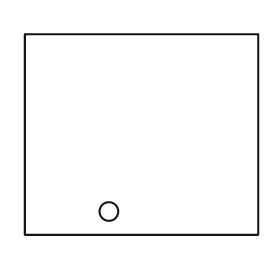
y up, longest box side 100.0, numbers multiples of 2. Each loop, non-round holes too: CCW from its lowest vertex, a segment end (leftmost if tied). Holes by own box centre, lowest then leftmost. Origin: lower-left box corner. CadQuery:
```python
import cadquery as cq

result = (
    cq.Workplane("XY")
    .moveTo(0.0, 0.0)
    .lineTo(100.0, 0.0)
    .lineTo(100.0, 86.0)
    .lineTo(0.0, 86.0)
    .close()
    .moveTo(36.0, 10.0)
    .circle(4.0)
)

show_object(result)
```